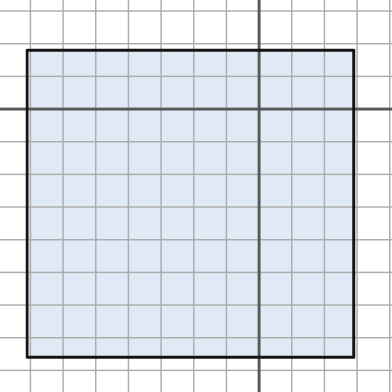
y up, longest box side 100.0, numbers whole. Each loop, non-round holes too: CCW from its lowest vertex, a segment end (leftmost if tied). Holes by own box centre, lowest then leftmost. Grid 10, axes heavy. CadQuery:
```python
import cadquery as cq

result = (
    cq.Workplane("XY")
    .moveTo(-71.0, -76.0)
    .lineTo(29.0, -76.0)
    .lineTo(29.0, 18.0)
    .lineTo(-71.0, 18.0)
    .close()
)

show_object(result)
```